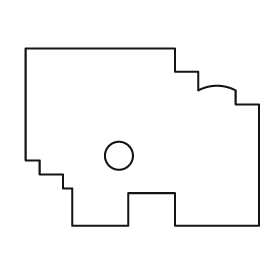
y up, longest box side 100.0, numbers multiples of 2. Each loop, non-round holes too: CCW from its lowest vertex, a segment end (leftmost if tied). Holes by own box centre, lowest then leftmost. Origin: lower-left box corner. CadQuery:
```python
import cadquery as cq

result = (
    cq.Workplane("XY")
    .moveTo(20.0, 0.0)
    .lineTo(44.0, 0.0)
    .lineTo(44.0, 14.0)
    .lineTo(64.0, 14.0)
    .lineTo(64.0, 0.0)
    .lineTo(100.0, 0.0)
    .lineTo(100.0, 52.0)
    .lineTo(90.0, 52.0)
    .lineTo(90.0, 58.0)
    .threePointArc((82.0, 60.0), (74.0, 58.0))
    .lineTo(74.0, 66.0)
    .lineTo(64.0, 66.0)
    .lineTo(64.0, 76.0)
    .lineTo(0.0, 76.0)
    .lineTo(0.0, 28.0)
    .lineTo(6.0, 28.0)
    .lineTo(6.0, 22.0)
    .lineTo(16.0, 22.0)
    .lineTo(16.0, 16.0)
    .lineTo(20.0, 16.0)
    .close()
    .moveTo(40.0, 30.0)
    .circle(6.0)
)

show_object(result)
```